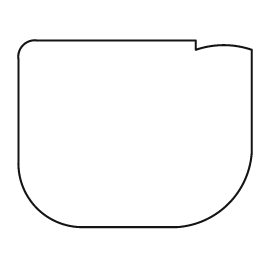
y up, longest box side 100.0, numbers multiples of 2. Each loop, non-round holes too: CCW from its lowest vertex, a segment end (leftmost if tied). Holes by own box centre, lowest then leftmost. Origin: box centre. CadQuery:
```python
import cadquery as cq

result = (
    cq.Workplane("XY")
    .moveTo(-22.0, -40.0)
    .lineTo(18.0, -40.0)
    .threePointArc((40.0, -30.0), (50.0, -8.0))
    .lineTo(50.0, 36.0)
    .threePointArc((38.0, 38.0), (26.0, 36.0))
    .lineTo(26.0, 40.0)
    .lineTo(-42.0, 40.0)
    .threePointArc((-48.0, 38.0), (-50.0, 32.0))
    .lineTo(-50.0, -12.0)
    .threePointArc((-42.0, -32.0), (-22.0, -40.0))
    .close()
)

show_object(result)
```